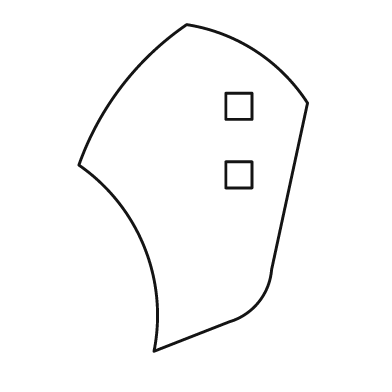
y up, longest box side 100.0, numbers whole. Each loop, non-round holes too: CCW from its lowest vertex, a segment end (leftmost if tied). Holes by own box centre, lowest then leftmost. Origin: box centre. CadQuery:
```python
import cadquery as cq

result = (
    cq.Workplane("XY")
    .moveTo(-12.0, -50.0)
    .lineTo(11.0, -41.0)
    .threePointArc((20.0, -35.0), (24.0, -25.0))
    .lineTo(35.0, 26.0)
    .threePointArc((19.0, 42.0), (-2.0, 50.0))
    .threePointArc((-22.0, 31.0), (-35.0, 7.0))
    .threePointArc((-15.0, -18.0), (-12.0, -50.0))
    .close()
    .moveTo(10.0, 0.0)
    .lineTo(18.0, 0.0)
    .lineTo(18.0, 8.0)
    .lineTo(10.0, 8.0)
    .close()
    .moveTo(10.0, 21.0)
    .lineTo(18.0, 21.0)
    .lineTo(18.0, 29.0)
    .lineTo(10.0, 29.0)
    .close()
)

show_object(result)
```